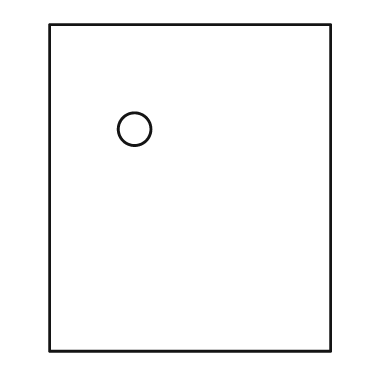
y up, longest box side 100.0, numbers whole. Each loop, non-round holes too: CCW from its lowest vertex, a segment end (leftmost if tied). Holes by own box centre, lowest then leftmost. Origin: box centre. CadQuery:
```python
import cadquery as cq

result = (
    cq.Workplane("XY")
    .moveTo(-43.0, -50.0)
    .lineTo(43.0, -50.0)
    .lineTo(43.0, 50.0)
    .lineTo(-43.0, 50.0)
    .close()
    .moveTo(-17.0, 18.0)
    .circle(5.0)
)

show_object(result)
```